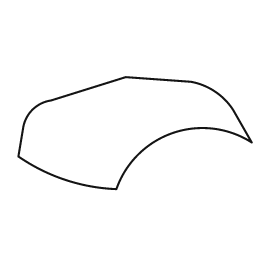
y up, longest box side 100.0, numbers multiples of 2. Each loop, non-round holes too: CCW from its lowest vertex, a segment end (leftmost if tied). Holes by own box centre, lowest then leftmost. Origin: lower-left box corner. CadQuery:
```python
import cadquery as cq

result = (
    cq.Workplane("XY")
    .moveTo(42.0, 0.0)
    .threePointArc((66.0, 24.0), (100.0, 20.0))
    .lineTo(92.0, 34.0)
    .threePointArc((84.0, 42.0), (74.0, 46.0))
    .lineTo(46.0, 48.0)
    .lineTo(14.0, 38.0)
    .threePointArc((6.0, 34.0), (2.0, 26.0))
    .lineTo(0.0, 14.0)
    .threePointArc((20.0, 4.0), (42.0, 0.0))
    .close()
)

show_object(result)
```